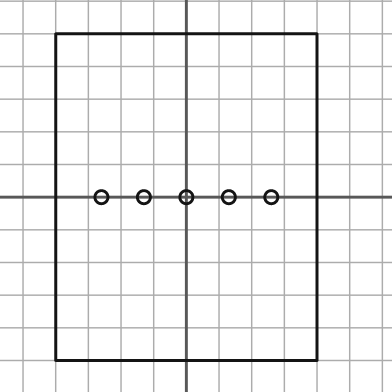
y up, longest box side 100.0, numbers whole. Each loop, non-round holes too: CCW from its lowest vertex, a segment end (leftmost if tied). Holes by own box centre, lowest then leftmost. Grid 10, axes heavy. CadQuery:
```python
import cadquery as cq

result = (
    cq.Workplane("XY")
    .moveTo(-40.0, -50.0)
    .lineTo(40.0, -50.0)
    .lineTo(40.0, 50.0)
    .lineTo(-40.0, 50.0)
    .close()
    .moveTo(-26.0, 0.0)
    .circle(2.0)
    .moveTo(-13.0, 0.0)
    .circle(2.0)
    .moveTo(0.0, 0.0)
    .circle(2.0)
    .moveTo(13.0, 0.0)
    .circle(2.0)
    .moveTo(26.0, 0.0)
    .circle(2.0)
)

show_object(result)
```